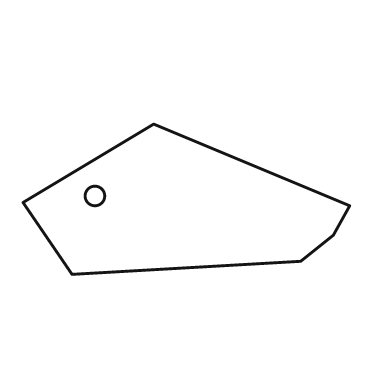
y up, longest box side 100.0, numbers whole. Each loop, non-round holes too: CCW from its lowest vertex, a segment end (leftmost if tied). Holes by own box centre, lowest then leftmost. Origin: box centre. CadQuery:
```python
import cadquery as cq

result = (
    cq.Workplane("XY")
    .moveTo(-35.0, -23.0)
    .lineTo(35.0, -19.0)
    .lineTo(45.0, -11.0)
    .lineTo(50.0, -2.0)
    .lineTo(-10.0, 23.0)
    .lineTo(-50.0, -1.0)
    .close()
    .moveTo(-28.0, 1.0)
    .circle(3.0)
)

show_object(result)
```